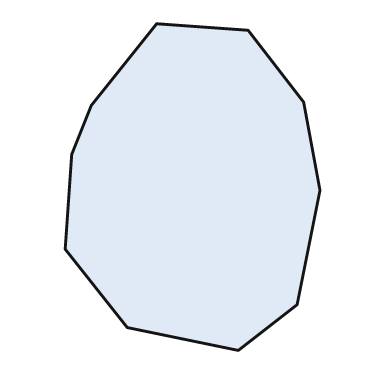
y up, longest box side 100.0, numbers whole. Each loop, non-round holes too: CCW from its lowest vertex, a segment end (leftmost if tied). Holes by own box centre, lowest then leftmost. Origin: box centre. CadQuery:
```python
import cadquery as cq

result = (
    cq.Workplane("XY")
    .moveTo(14.0, -50.0)
    .lineTo(32.0, -36.0)
    .lineTo(39.0, -1.0)
    .lineTo(34.0, 26.0)
    .lineTo(17.0, 48.0)
    .lineTo(-11.0, 50.0)
    .lineTo(-31.0, 25.0)
    .lineTo(-37.0, 10.0)
    .lineTo(-39.0, -19.0)
    .lineTo(-20.0, -43.0)
    .close()
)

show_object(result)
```